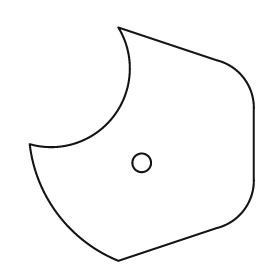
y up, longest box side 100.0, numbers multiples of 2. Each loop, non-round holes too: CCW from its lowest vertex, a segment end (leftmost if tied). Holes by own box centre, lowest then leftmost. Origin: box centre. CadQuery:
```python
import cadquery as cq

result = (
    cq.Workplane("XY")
    .moveTo(-10.0, -50.0)
    .lineTo(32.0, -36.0)
    .threePointArc((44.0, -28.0), (48.0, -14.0))
    .lineTo(48.0, 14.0)
    .threePointArc((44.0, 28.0), (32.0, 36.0))
    .lineTo(-10.0, 50.0)
    .threePointArc((-12.0, 12.0), (-48.0, 0.0))
    .threePointArc((-36.0, -30.0), (-10.0, -50.0))
    .close()
    .moveTo(0.0, -8.0)
    .circle(4.0)
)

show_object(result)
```